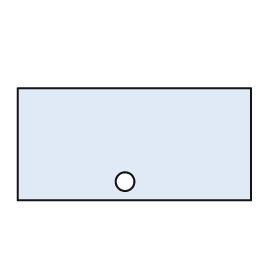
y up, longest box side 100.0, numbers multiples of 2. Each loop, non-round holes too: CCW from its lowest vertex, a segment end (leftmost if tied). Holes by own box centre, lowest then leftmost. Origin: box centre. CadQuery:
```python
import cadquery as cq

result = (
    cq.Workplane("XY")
    .moveTo(-50.0, -24.0)
    .lineTo(50.0, -24.0)
    .lineTo(50.0, 24.0)
    .lineTo(-50.0, 24.0)
    .close()
    .moveTo(-4.0, -16.0)
    .circle(4.0)
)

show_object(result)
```